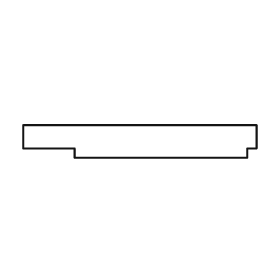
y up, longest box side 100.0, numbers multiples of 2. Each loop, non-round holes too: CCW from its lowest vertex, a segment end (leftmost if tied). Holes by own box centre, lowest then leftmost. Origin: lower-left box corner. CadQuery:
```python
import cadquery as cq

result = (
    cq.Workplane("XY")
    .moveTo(22.0, 0.0)
    .lineTo(96.0, 0.0)
    .lineTo(96.0, 4.0)
    .lineTo(100.0, 4.0)
    .lineTo(100.0, 14.0)
    .lineTo(0.0, 14.0)
    .lineTo(0.0, 4.0)
    .lineTo(22.0, 4.0)
    .close()
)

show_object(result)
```